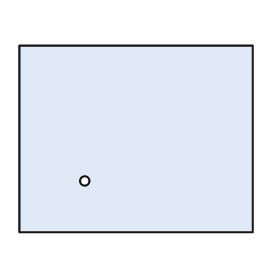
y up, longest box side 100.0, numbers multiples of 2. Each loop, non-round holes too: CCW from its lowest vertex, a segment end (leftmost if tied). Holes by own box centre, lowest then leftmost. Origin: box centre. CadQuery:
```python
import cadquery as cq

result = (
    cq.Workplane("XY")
    .moveTo(-50.0, -40.0)
    .lineTo(50.0, -40.0)
    .lineTo(50.0, 40.0)
    .lineTo(-50.0, 40.0)
    .close()
    .moveTo(-22.0, -18.0)
    .circle(2.0)
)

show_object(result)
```